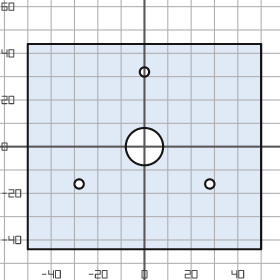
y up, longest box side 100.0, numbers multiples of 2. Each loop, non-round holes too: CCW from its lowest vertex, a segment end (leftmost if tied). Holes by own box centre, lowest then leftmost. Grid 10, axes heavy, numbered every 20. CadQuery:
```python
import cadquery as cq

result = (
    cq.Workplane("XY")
    .moveTo(-50.0, -44.0)
    .lineTo(50.0, -44.0)
    .lineTo(50.0, 44.0)
    .lineTo(-50.0, 44.0)
    .close()
    .moveTo(-28.0, -16.0)
    .circle(2.0)
    .moveTo(28.0, -16.0)
    .circle(2.0)
    .moveTo(0.0, 0.0)
    .circle(8.0)
    .moveTo(0.0, 32.0)
    .circle(2.0)
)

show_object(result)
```